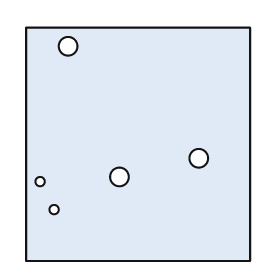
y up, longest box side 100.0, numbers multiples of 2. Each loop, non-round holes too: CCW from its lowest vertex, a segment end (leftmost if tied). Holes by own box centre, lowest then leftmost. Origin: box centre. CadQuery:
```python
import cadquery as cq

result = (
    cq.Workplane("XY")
    .moveTo(-48.0, -50.0)
    .lineTo(48.0, -50.0)
    .lineTo(48.0, 50.0)
    .lineTo(-48.0, 50.0)
    .close()
    .moveTo(-36.0, -28.0)
    .circle(2.0)
    .moveTo(-42.0, -16.0)
    .circle(2.0)
    .moveTo(-8.0, -14.0)
    .circle(4.0)
    .moveTo(26.0, -6.0)
    .circle(4.0)
    .moveTo(-30.0, 42.0)
    .circle(4.0)
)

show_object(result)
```